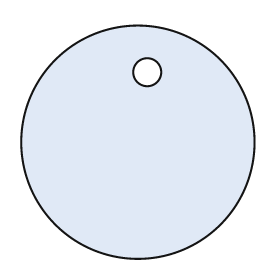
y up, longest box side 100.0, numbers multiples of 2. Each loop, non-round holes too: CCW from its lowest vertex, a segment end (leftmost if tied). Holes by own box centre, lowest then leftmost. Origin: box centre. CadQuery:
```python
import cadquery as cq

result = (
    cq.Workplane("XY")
    .moveTo(0.0, 0.0)
    .circle(50.0)
    .moveTo(4.0, 30.0)
    .circle(6.0)
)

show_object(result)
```